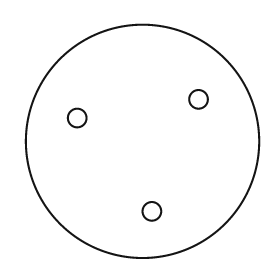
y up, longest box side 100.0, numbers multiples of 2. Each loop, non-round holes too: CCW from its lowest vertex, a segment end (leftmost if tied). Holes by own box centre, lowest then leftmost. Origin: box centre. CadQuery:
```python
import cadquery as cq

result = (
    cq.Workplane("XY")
    .moveTo(0.0, 0.0)
    .circle(50.0)
    .moveTo(4.0, -30.0)
    .circle(4.0)
    .moveTo(-28.0, 10.0)
    .circle(4.0)
    .moveTo(24.0, 18.0)
    .circle(4.0)
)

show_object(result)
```